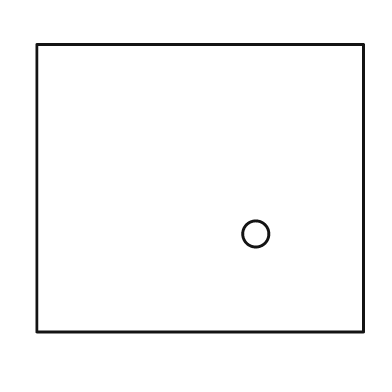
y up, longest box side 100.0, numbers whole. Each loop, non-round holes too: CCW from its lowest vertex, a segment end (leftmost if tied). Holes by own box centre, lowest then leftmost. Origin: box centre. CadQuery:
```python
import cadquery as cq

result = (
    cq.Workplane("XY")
    .moveTo(-50.0, -44.0)
    .lineTo(50.0, -44.0)
    .lineTo(50.0, 44.0)
    .lineTo(-50.0, 44.0)
    .close()
    .moveTo(17.0, -14.0)
    .circle(4.0)
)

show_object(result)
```